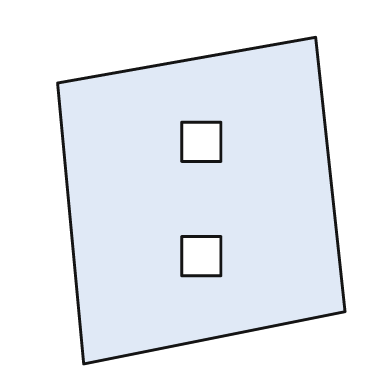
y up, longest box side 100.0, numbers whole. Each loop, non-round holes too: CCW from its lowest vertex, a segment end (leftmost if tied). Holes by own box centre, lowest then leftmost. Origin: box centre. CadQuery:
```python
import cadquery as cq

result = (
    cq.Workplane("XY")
    .moveTo(-36.0, -50.0)
    .lineTo(44.0, -34.0)
    .lineTo(35.0, 50.0)
    .lineTo(-44.0, 36.0)
    .close()
    .moveTo(-6.0, -23.0)
    .lineTo(6.0, -23.0)
    .lineTo(6.0, -11.0)
    .lineTo(-6.0, -11.0)
    .close()
    .moveTo(-6.0, 12.0)
    .lineTo(6.0, 12.0)
    .lineTo(6.0, 24.0)
    .lineTo(-6.0, 24.0)
    .close()
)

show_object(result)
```